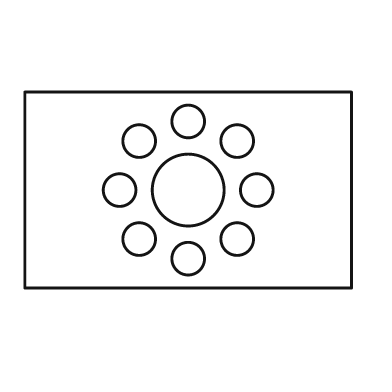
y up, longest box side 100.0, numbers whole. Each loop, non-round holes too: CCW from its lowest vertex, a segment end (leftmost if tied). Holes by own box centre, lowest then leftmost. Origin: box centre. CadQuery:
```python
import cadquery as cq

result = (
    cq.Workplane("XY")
    .moveTo(-50.0, -30.0)
    .lineTo(50.0, -30.0)
    .lineTo(50.0, 30.0)
    .lineTo(-50.0, 30.0)
    .close()
    .moveTo(0.0, -21.0)
    .circle(5.0)
    .moveTo(-15.0, -15.0)
    .circle(5.0)
    .moveTo(15.0, -15.0)
    .circle(5.0)
    .moveTo(-21.0, 0.0)
    .circle(5.0)
    .moveTo(0.0, 0.0)
    .circle(11.0)
    .moveTo(21.0, 0.0)
    .circle(5.0)
    .moveTo(-15.0, 15.0)
    .circle(5.0)
    .moveTo(15.0, 15.0)
    .circle(5.0)
    .moveTo(0.0, 21.0)
    .circle(5.0)
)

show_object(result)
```